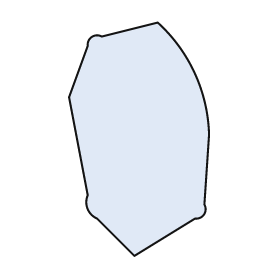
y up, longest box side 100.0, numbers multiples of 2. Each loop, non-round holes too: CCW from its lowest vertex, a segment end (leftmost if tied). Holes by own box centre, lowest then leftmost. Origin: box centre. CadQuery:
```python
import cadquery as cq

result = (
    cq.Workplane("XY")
    .moveTo(-2.0, -50.0)
    .lineTo(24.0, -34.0)
    .threePointArc((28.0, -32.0), (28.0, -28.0))
    .lineTo(30.0, 2.0)
    .threePointArc((24.0, 28.0), (8.0, 50.0))
    .lineTo(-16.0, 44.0)
    .threePointArc((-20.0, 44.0), (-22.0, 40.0))
    .lineTo(-30.0, 18.0)
    .lineTo(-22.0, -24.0)
    .threePointArc((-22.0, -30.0), (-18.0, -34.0))
    .close()
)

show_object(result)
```